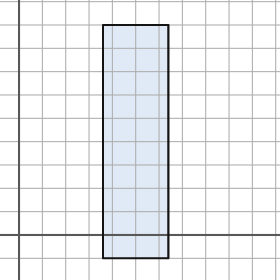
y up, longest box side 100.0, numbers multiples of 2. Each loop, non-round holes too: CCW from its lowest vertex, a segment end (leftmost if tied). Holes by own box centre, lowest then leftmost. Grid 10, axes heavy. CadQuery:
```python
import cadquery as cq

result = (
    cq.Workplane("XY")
    .moveTo(36.0, -10.0)
    .lineTo(64.0, -10.0)
    .lineTo(64.0, 90.0)
    .lineTo(36.0, 90.0)
    .close()
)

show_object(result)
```